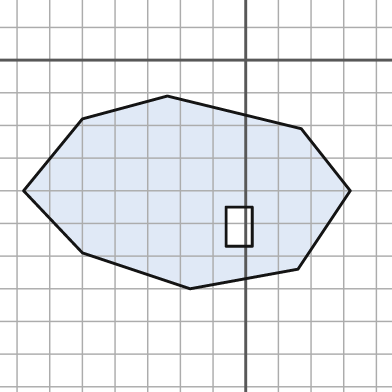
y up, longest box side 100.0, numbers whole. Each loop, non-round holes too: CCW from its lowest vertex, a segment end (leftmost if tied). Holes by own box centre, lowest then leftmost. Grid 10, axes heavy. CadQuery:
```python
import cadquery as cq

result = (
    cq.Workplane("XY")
    .moveTo(-17.0, -70.0)
    .lineTo(16.0, -64.0)
    .lineTo(32.0, -40.0)
    .lineTo(17.0, -21.0)
    .lineTo(-24.0, -11.0)
    .lineTo(-50.0, -18.0)
    .lineTo(-68.0, -40.0)
    .lineTo(-50.0, -59.0)
    .close()
    .moveTo(-6.0, -57.0)
    .lineTo(2.0, -57.0)
    .lineTo(2.0, -45.0)
    .lineTo(-6.0, -45.0)
    .close()
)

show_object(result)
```